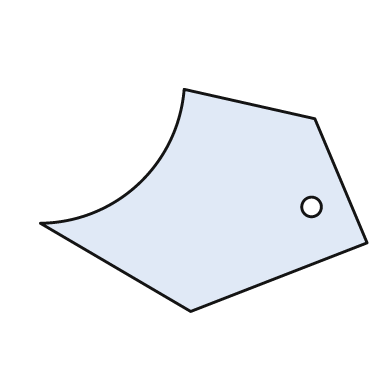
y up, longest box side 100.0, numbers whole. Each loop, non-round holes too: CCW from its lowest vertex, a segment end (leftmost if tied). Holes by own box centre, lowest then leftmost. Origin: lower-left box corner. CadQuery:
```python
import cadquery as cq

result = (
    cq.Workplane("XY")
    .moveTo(46.0, 0.0)
    .lineTo(100.0, 21.0)
    .lineTo(84.0, 59.0)
    .lineTo(44.0, 68.0)
    .threePointArc((30.0, 39.0), (0.0, 27.0))
    .close()
    .moveTo(83.0, 32.0)
    .circle(3.0)
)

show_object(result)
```